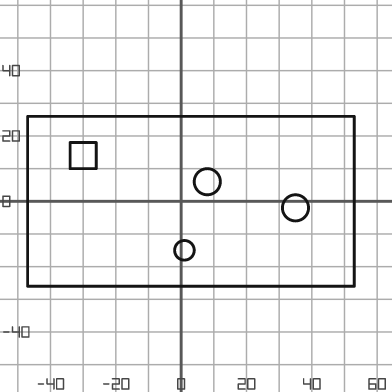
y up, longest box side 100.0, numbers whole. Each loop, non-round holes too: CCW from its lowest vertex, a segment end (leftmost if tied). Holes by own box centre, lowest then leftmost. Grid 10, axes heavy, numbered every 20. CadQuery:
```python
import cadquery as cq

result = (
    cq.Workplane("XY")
    .moveTo(-47.0, -26.0)
    .lineTo(53.0, -26.0)
    .lineTo(53.0, 26.0)
    .lineTo(-47.0, 26.0)
    .close()
    .moveTo(1.0, -15.0)
    .circle(3.0)
    .moveTo(35.0, -2.0)
    .circle(4.0)
    .moveTo(8.0, 6.0)
    .circle(4.0)
    .moveTo(-34.0, 10.0)
    .lineTo(-26.0, 10.0)
    .lineTo(-26.0, 18.0)
    .lineTo(-34.0, 18.0)
    .close()
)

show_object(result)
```